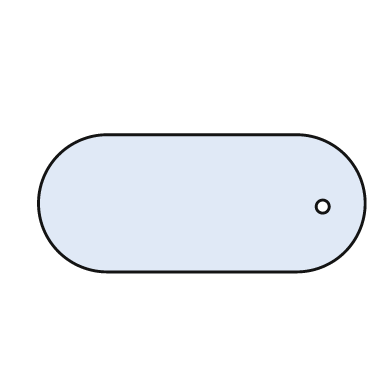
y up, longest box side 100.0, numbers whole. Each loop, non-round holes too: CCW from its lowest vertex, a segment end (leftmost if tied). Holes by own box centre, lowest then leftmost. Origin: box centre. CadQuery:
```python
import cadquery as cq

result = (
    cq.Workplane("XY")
    .moveTo(-29.0, -21.0)
    .lineTo(29.0, -21.0)
    .threePointArc((50.0, 0.0), (29.0, 21.0))
    .lineTo(-29.0, 21.0)
    .threePointArc((-50.0, 0.0), (-29.0, -21.0))
    .close()
    .moveTo(37.0, -1.0)
    .circle(2.0)
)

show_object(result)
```